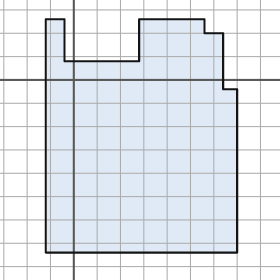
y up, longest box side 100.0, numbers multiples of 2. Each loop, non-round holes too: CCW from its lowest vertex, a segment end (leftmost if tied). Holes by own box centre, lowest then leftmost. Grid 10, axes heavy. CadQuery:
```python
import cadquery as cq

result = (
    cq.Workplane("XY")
    .moveTo(-12.0, -74.0)
    .lineTo(70.0, -74.0)
    .lineTo(70.0, -4.0)
    .lineTo(64.0, -4.0)
    .lineTo(64.0, 20.0)
    .lineTo(56.0, 20.0)
    .lineTo(56.0, 26.0)
    .lineTo(28.0, 26.0)
    .lineTo(28.0, 8.0)
    .lineTo(-4.0, 8.0)
    .lineTo(-4.0, 26.0)
    .lineTo(-12.0, 26.0)
    .close()
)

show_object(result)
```